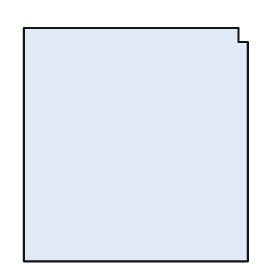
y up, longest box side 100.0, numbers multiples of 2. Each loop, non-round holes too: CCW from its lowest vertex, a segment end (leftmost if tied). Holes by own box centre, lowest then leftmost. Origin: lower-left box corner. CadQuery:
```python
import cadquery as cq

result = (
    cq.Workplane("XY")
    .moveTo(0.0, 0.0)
    .lineTo(96.0, 0.0)
    .lineTo(96.0, 94.0)
    .lineTo(92.0, 94.0)
    .lineTo(92.0, 100.0)
    .lineTo(0.0, 100.0)
    .close()
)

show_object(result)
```